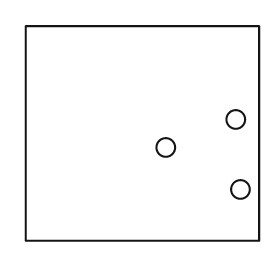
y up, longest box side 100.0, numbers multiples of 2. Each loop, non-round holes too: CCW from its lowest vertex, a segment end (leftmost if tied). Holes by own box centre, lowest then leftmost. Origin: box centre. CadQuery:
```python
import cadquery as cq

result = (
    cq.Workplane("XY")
    .moveTo(-50.0, -46.0)
    .lineTo(50.0, -46.0)
    .lineTo(50.0, 46.0)
    .lineTo(-50.0, 46.0)
    .close()
    .moveTo(42.0, -24.0)
    .circle(4.0)
    .moveTo(10.0, -6.0)
    .circle(4.0)
    .moveTo(40.0, 6.0)
    .circle(4.0)
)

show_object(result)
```